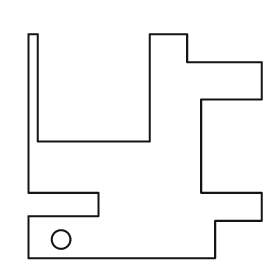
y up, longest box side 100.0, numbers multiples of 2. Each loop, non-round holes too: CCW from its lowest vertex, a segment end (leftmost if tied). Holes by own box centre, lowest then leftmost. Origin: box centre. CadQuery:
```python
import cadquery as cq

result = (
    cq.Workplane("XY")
    .moveTo(-50.0, -48.0)
    .lineTo(30.0, -48.0)
    .lineTo(30.0, -32.0)
    .lineTo(50.0, -32.0)
    .lineTo(50.0, -20.0)
    .lineTo(24.0, -20.0)
    .lineTo(24.0, 20.0)
    .lineTo(50.0, 20.0)
    .lineTo(50.0, 36.0)
    .lineTo(18.0, 36.0)
    .lineTo(18.0, 48.0)
    .lineTo(2.0, 48.0)
    .lineTo(2.0, 2.0)
    .lineTo(-46.0, 2.0)
    .lineTo(-46.0, 48.0)
    .lineTo(-50.0, 48.0)
    .lineTo(-50.0, -20.0)
    .lineTo(-20.0, -20.0)
    .lineTo(-20.0, -30.0)
    .lineTo(-50.0, -30.0)
    .close()
    .moveTo(-36.0, -40.0)
    .circle(4.0)
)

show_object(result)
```